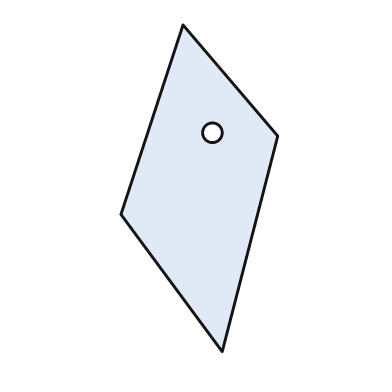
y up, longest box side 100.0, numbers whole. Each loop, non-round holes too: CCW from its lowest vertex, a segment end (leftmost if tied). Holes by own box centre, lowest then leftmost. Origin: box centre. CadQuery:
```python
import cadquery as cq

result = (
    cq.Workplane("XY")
    .moveTo(7.0, -50.0)
    .lineTo(24.0, 16.0)
    .lineTo(-5.0, 50.0)
    .lineTo(-24.0, -8.0)
    .close()
    .moveTo(4.0, 17.0)
    .circle(3.0)
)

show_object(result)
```